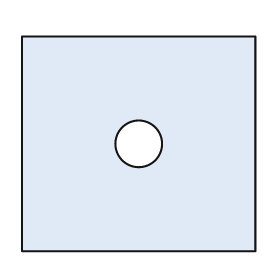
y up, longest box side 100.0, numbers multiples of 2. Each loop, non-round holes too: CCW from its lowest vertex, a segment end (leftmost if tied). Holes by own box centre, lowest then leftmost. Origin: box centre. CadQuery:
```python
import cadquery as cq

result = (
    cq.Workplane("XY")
    .moveTo(-50.0, -46.0)
    .lineTo(50.0, -46.0)
    .lineTo(50.0, 46.0)
    .lineTo(-50.0, 46.0)
    .close()
    .moveTo(0.0, 0.0)
    .circle(10.0)
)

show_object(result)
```